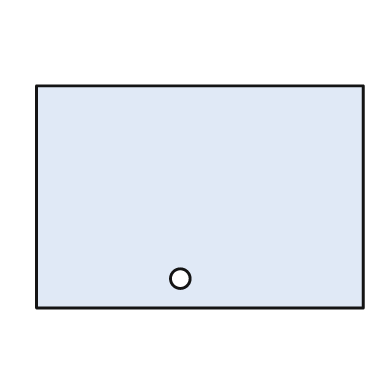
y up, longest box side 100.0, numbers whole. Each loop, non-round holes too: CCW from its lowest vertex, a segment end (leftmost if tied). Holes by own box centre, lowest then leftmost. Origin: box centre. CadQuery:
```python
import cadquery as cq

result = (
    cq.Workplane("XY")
    .moveTo(-50.0, -34.0)
    .lineTo(50.0, -34.0)
    .lineTo(50.0, 34.0)
    .lineTo(-50.0, 34.0)
    .close()
    .moveTo(-6.0, -25.0)
    .circle(3.0)
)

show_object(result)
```